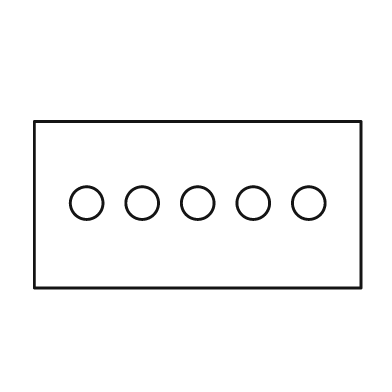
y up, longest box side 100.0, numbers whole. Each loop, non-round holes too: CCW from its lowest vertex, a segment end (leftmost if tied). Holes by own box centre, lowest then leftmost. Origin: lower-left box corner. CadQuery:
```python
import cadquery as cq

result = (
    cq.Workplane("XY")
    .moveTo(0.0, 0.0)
    .lineTo(100.0, 0.0)
    .lineTo(100.0, 51.0)
    .lineTo(0.0, 51.0)
    .close()
    .moveTo(16.0, 26.0)
    .circle(5.0)
    .moveTo(33.0, 26.0)
    .circle(5.0)
    .moveTo(50.0, 26.0)
    .circle(5.0)
    .moveTo(67.0, 26.0)
    .circle(5.0)
    .moveTo(84.0, 26.0)
    .circle(5.0)
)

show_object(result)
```